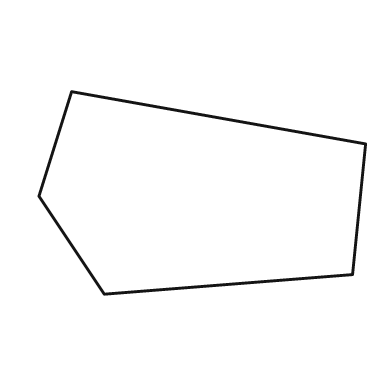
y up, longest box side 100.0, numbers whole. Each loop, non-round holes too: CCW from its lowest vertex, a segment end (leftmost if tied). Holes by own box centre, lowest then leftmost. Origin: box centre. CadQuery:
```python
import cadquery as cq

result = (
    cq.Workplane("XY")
    .moveTo(-30.0, -31.0)
    .lineTo(46.0, -25.0)
    .lineTo(50.0, 15.0)
    .lineTo(-40.0, 31.0)
    .lineTo(-50.0, -1.0)
    .close()
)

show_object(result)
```